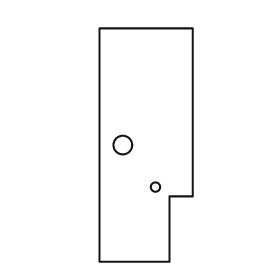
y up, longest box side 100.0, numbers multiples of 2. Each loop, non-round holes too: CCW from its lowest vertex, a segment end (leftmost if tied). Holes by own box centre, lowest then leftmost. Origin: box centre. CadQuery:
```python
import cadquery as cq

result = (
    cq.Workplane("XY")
    .moveTo(-20.0, -50.0)
    .lineTo(10.0, -50.0)
    .lineTo(10.0, -22.0)
    .lineTo(20.0, -22.0)
    .lineTo(20.0, 50.0)
    .lineTo(-20.0, 50.0)
    .close()
    .moveTo(4.0, -18.0)
    .circle(2.0)
    .moveTo(-10.0, 0.0)
    .circle(4.0)
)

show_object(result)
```